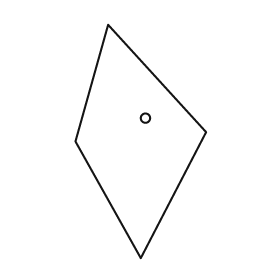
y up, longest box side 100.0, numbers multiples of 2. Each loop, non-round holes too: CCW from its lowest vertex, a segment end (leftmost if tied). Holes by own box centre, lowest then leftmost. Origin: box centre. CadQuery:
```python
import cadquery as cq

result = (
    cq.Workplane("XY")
    .moveTo(0.0, -50.0)
    .lineTo(28.0, 4.0)
    .lineTo(-14.0, 50.0)
    .lineTo(-28.0, 0.0)
    .close()
    .moveTo(2.0, 10.0)
    .circle(2.0)
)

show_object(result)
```